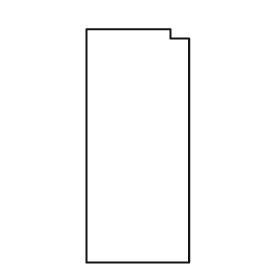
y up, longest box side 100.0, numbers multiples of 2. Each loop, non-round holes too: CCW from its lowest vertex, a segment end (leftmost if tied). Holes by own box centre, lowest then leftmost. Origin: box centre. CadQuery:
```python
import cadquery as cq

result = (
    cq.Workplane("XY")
    .moveTo(-22.0, -50.0)
    .lineTo(22.0, -50.0)
    .lineTo(22.0, 46.0)
    .lineTo(14.0, 46.0)
    .lineTo(14.0, 50.0)
    .lineTo(-22.0, 50.0)
    .close()
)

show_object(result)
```